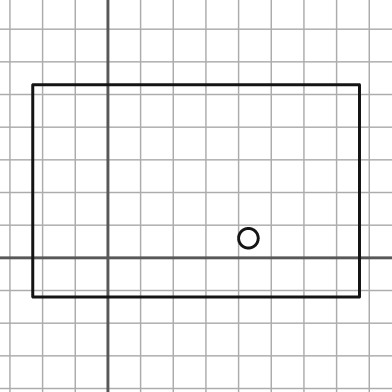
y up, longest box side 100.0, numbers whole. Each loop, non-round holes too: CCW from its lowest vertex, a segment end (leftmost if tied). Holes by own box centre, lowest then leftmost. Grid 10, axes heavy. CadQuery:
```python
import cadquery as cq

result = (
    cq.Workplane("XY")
    .moveTo(-23.0, -12.0)
    .lineTo(77.0, -12.0)
    .lineTo(77.0, 53.0)
    .lineTo(-23.0, 53.0)
    .close()
    .moveTo(43.0, 6.0)
    .circle(3.0)
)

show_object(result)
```